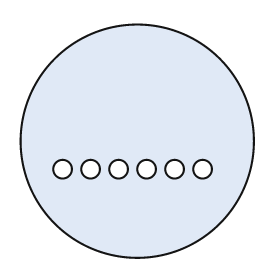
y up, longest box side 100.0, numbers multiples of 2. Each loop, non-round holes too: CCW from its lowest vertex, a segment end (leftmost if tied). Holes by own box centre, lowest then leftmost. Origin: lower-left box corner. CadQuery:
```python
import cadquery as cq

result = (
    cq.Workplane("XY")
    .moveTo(50.0, 50.0)
    .circle(50.0)
    .moveTo(18.0, 38.0)
    .circle(4.0)
    .moveTo(30.0, 38.0)
    .circle(4.0)
    .moveTo(42.0, 38.0)
    .circle(4.0)
    .moveTo(54.0, 38.0)
    .circle(4.0)
    .moveTo(66.0, 38.0)
    .circle(4.0)
    .moveTo(78.0, 38.0)
    .circle(4.0)
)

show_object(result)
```